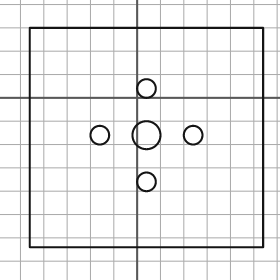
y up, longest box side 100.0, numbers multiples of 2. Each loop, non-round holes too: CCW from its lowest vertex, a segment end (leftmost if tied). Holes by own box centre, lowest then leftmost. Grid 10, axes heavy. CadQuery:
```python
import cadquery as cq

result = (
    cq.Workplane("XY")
    .moveTo(-46.0, -64.0)
    .lineTo(54.0, -64.0)
    .lineTo(54.0, 30.0)
    .lineTo(-46.0, 30.0)
    .close()
    .moveTo(4.0, -36.0)
    .circle(4.0)
    .moveTo(-16.0, -16.0)
    .circle(4.0)
    .moveTo(4.0, -16.0)
    .circle(6.0)
    .moveTo(24.0, -16.0)
    .circle(4.0)
    .moveTo(4.0, 4.0)
    .circle(4.0)
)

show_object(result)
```